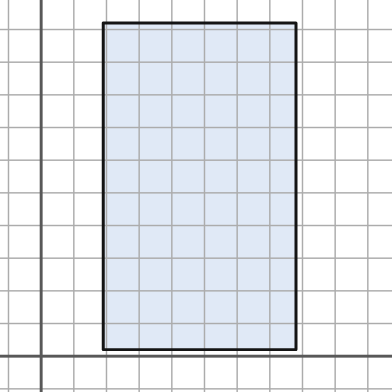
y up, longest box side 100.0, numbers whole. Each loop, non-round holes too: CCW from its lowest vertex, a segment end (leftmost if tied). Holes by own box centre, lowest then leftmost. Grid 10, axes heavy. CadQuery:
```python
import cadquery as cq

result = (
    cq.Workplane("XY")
    .moveTo(19.0, 2.0)
    .lineTo(78.0, 2.0)
    .lineTo(78.0, 102.0)
    .lineTo(19.0, 102.0)
    .close()
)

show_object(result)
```